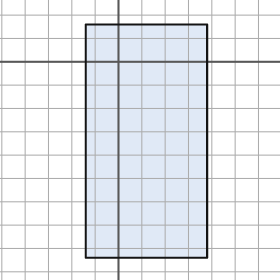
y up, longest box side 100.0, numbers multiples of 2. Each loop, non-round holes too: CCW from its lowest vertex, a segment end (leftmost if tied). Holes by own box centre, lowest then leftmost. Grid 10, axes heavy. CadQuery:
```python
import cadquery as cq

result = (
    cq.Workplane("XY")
    .moveTo(-14.0, -84.0)
    .lineTo(38.0, -84.0)
    .lineTo(38.0, 16.0)
    .lineTo(-14.0, 16.0)
    .close()
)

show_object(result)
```